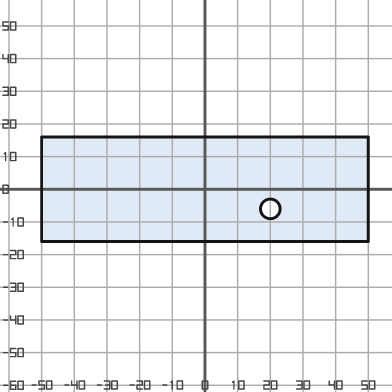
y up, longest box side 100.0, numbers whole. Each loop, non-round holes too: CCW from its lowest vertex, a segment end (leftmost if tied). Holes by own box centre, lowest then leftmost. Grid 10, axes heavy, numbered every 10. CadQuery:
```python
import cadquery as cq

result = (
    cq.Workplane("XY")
    .moveTo(-50.0, -16.0)
    .lineTo(50.0, -16.0)
    .lineTo(50.0, 16.0)
    .lineTo(-50.0, 16.0)
    .close()
    .moveTo(20.0, -6.0)
    .circle(3.0)
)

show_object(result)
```